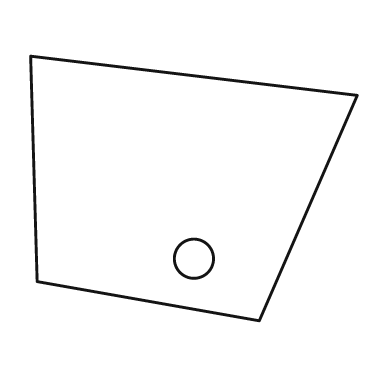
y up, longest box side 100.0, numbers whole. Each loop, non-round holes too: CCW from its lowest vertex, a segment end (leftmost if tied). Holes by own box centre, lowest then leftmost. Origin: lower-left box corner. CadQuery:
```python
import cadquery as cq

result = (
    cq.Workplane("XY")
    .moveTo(70.0, 0.0)
    .lineTo(100.0, 69.0)
    .lineTo(0.0, 81.0)
    .lineTo(2.0, 12.0)
    .close()
    .moveTo(50.0, 19.0)
    .circle(6.0)
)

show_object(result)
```